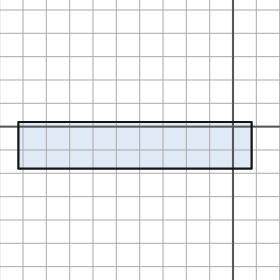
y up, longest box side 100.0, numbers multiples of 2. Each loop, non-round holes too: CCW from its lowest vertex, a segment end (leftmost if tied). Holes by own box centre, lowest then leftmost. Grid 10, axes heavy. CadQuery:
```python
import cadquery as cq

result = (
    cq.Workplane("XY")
    .moveTo(-92.0, -18.0)
    .lineTo(8.0, -18.0)
    .lineTo(8.0, 2.0)
    .lineTo(-92.0, 2.0)
    .close()
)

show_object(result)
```